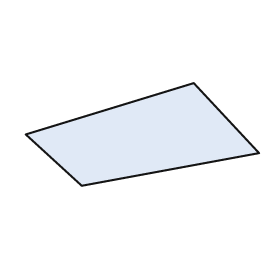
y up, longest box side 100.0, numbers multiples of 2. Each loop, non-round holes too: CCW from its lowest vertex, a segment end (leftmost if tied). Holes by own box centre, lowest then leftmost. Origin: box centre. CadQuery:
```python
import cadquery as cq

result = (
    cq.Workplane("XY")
    .moveTo(-26.0, -22.0)
    .lineTo(50.0, -8.0)
    .lineTo(22.0, 22.0)
    .lineTo(-50.0, 0.0)
    .close()
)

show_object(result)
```